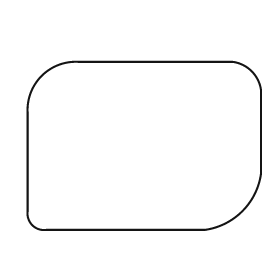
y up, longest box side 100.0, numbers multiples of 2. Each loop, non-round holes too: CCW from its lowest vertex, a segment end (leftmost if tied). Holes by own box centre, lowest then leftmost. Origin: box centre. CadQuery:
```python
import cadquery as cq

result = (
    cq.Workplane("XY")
    .moveTo(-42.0, -36.0)
    .lineTo(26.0, -36.0)
    .threePointArc((42.0, -28.0), (50.0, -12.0))
    .lineTo(50.0, 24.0)
    .threePointArc((46.0, 32.0), (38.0, 36.0))
    .lineTo(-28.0, 36.0)
    .threePointArc((-44.0, 30.0), (-50.0, 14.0))
    .lineTo(-50.0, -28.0)
    .threePointArc((-48.0, -34.0), (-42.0, -36.0))
    .close()
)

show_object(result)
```